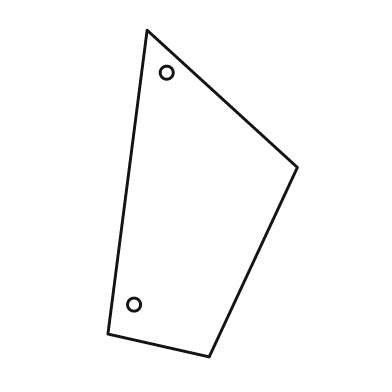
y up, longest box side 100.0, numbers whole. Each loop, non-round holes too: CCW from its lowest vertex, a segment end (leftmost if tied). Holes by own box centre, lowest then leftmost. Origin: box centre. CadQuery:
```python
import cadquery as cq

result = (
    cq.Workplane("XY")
    .moveTo(2.0, -50.0)
    .lineTo(29.0, 8.0)
    .lineTo(-17.0, 50.0)
    .lineTo(-29.0, -43.0)
    .close()
    .moveTo(-21.0, -34.0)
    .circle(2.0)
    .moveTo(-11.0, 37.0)
    .circle(2.0)
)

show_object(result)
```